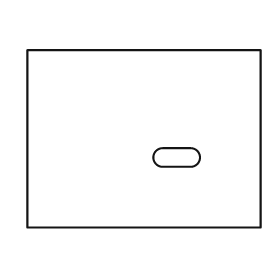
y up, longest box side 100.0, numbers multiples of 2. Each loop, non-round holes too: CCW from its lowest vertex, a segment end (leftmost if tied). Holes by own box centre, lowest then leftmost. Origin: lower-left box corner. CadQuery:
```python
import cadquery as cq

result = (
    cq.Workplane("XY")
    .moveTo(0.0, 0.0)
    .lineTo(100.0, 0.0)
    .lineTo(100.0, 76.0)
    .lineTo(0.0, 76.0)
    .close()
    .moveTo(58.0, 26.0)
    .lineTo(70.0, 26.0)
    .threePointArc((74.0, 30.0), (70.0, 34.0))
    .lineTo(58.0, 34.0)
    .threePointArc((54.0, 30.0), (58.0, 26.0))
    .close()
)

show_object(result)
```